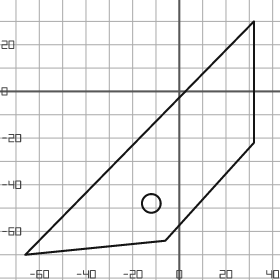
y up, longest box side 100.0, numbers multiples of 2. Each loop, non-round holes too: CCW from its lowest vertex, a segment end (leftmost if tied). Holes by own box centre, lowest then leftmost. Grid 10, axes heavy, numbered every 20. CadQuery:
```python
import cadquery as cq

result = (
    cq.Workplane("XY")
    .moveTo(-66.0, -70.0)
    .lineTo(-6.0, -64.0)
    .lineTo(32.0, -22.0)
    .lineTo(32.0, 30.0)
    .close()
    .moveTo(-12.0, -48.0)
    .circle(4.0)
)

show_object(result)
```